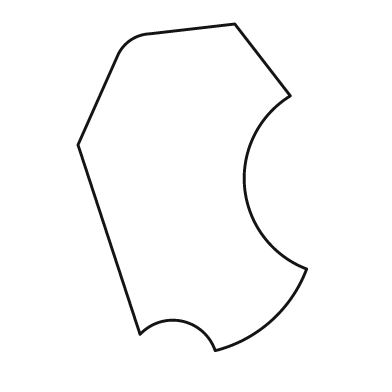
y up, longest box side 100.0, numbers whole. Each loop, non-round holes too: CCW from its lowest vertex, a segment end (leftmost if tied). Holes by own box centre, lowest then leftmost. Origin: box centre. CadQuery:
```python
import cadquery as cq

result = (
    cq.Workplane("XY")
    .moveTo(7.0, -50.0)
    .threePointArc((24.0, -41.0), (35.0, -25.0))
    .threePointArc((16.0, 0.0), (30.0, 28.0))
    .lineTo(13.0, 50.0)
    .lineTo(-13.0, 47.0)
    .threePointArc((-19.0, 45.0), (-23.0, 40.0))
    .lineTo(-35.0, 13.0)
    .lineTo(-16.0, -45.0)
    .threePointArc((-3.0, -41.0), (7.0, -50.0))
    .close()
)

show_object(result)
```